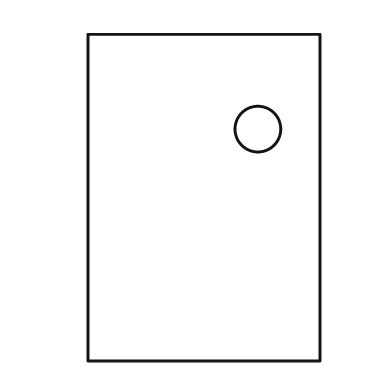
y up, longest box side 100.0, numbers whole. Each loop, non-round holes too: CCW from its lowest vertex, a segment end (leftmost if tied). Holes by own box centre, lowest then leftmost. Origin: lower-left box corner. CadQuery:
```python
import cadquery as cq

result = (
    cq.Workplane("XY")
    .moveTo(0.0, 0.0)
    .lineTo(71.0, 0.0)
    .lineTo(71.0, 100.0)
    .lineTo(0.0, 100.0)
    .close()
    .moveTo(52.0, 71.0)
    .circle(7.0)
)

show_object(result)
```